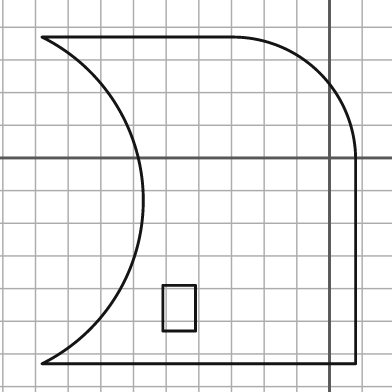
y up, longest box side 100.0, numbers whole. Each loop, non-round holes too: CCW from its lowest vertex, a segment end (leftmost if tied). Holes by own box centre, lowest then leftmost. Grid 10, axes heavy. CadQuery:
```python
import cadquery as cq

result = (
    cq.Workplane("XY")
    .moveTo(-88.0, -63.0)
    .lineTo(8.0, -63.0)
    .lineTo(8.0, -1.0)
    .threePointArc((-3.0, 26.0), (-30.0, 37.0))
    .lineTo(-88.0, 37.0)
    .threePointArc((-57.0, -13.0), (-88.0, -63.0))
    .close()
    .moveTo(-51.0, -53.0)
    .lineTo(-41.0, -53.0)
    .lineTo(-41.0, -39.0)
    .lineTo(-51.0, -39.0)
    .close()
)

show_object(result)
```